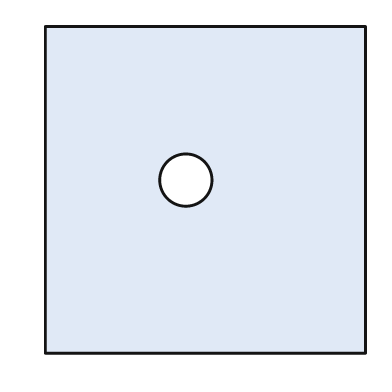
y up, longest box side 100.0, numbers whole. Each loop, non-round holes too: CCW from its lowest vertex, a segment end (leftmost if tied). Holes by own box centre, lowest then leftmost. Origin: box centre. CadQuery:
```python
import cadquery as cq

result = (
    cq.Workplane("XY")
    .moveTo(-49.0, -50.0)
    .lineTo(49.0, -50.0)
    .lineTo(49.0, 50.0)
    .lineTo(-49.0, 50.0)
    .close()
    .moveTo(-6.0, 3.0)
    .circle(8.0)
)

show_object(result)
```